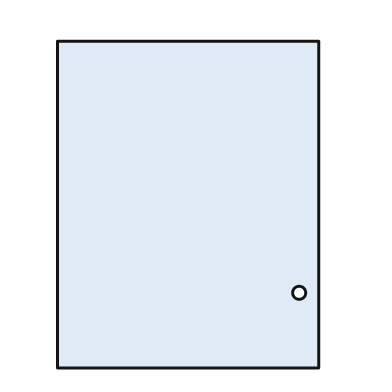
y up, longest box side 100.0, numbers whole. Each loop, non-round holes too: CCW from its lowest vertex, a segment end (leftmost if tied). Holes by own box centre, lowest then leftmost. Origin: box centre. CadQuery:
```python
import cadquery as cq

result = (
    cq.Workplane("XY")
    .moveTo(-40.0, -50.0)
    .lineTo(40.0, -50.0)
    .lineTo(40.0, 50.0)
    .lineTo(-40.0, 50.0)
    .close()
    .moveTo(34.0, -27.0)
    .circle(2.0)
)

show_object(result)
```